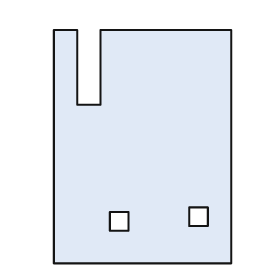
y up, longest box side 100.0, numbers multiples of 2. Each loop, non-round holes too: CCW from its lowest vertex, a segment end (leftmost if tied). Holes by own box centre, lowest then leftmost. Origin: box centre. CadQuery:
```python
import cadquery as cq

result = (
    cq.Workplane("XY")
    .moveTo(-38.0, -50.0)
    .lineTo(38.0, -50.0)
    .lineTo(38.0, 50.0)
    .lineTo(-18.0, 50.0)
    .lineTo(-18.0, 18.0)
    .lineTo(-28.0, 18.0)
    .lineTo(-28.0, 50.0)
    .lineTo(-38.0, 50.0)
    .close()
    .moveTo(-14.0, -36.0)
    .lineTo(-6.0, -36.0)
    .lineTo(-6.0, -28.0)
    .lineTo(-14.0, -28.0)
    .close()
    .moveTo(20.0, -34.0)
    .lineTo(28.0, -34.0)
    .lineTo(28.0, -26.0)
    .lineTo(20.0, -26.0)
    .close()
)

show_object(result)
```